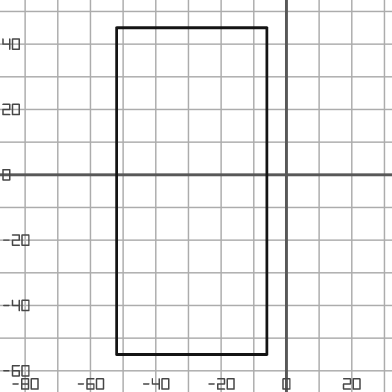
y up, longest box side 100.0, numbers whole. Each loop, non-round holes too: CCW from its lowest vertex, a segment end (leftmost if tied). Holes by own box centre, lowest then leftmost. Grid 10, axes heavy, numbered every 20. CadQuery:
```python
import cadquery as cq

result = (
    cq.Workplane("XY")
    .moveTo(-52.0, -55.0)
    .lineTo(-6.0, -55.0)
    .lineTo(-6.0, 45.0)
    .lineTo(-52.0, 45.0)
    .close()
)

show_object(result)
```